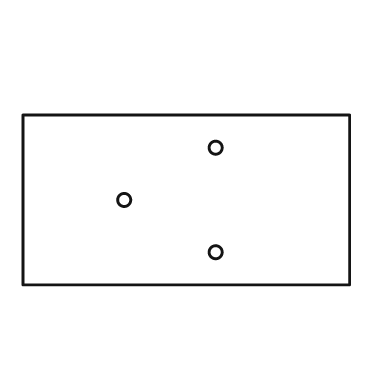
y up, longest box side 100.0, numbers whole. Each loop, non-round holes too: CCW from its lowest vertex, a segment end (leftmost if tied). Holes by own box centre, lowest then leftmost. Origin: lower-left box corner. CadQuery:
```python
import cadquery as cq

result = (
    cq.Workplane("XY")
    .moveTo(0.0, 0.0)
    .lineTo(100.0, 0.0)
    .lineTo(100.0, 52.0)
    .lineTo(0.0, 52.0)
    .close()
    .moveTo(59.0, 10.0)
    .circle(2.0)
    .moveTo(31.0, 26.0)
    .circle(2.0)
    .moveTo(59.0, 42.0)
    .circle(2.0)
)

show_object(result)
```